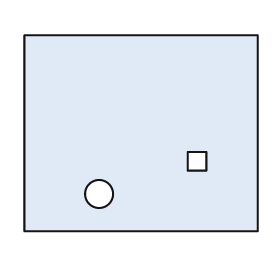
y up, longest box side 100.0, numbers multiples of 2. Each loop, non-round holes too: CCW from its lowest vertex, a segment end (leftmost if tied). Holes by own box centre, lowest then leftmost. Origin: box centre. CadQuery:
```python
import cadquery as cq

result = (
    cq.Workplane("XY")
    .moveTo(-50.0, -42.0)
    .lineTo(50.0, -42.0)
    .lineTo(50.0, 42.0)
    .lineTo(-50.0, 42.0)
    .close()
    .moveTo(-18.0, -26.0)
    .circle(6.0)
    .moveTo(20.0, -16.0)
    .lineTo(28.0, -16.0)
    .lineTo(28.0, -8.0)
    .lineTo(20.0, -8.0)
    .close()
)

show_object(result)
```